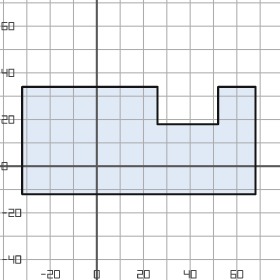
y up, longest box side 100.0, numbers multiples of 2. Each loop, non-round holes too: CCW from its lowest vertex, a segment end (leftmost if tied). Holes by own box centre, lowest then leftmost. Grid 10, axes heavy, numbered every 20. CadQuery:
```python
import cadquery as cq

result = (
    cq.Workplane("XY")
    .moveTo(-32.0, -12.0)
    .lineTo(68.0, -12.0)
    .lineTo(68.0, 34.0)
    .lineTo(52.0, 34.0)
    .lineTo(52.0, 18.0)
    .lineTo(26.0, 18.0)
    .lineTo(26.0, 34.0)
    .lineTo(-32.0, 34.0)
    .close()
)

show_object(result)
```